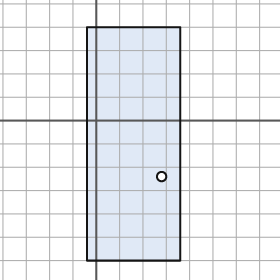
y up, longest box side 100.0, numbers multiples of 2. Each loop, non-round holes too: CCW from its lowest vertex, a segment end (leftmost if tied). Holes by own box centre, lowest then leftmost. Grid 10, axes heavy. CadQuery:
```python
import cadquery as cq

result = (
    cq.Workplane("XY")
    .moveTo(-4.0, -60.0)
    .lineTo(36.0, -60.0)
    .lineTo(36.0, 40.0)
    .lineTo(-4.0, 40.0)
    .close()
    .moveTo(28.0, -24.0)
    .circle(2.0)
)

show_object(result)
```